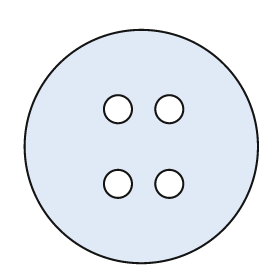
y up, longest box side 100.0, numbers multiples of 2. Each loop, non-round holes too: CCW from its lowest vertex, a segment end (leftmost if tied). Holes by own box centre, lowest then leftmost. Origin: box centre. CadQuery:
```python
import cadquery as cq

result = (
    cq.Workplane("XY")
    .moveTo(0.0, 0.0)
    .circle(50.0)
    .moveTo(-10.0, -16.0)
    .circle(6.0)
    .moveTo(12.0, -16.0)
    .circle(6.0)
    .moveTo(-10.0, 16.0)
    .circle(6.0)
    .moveTo(12.0, 16.0)
    .circle(6.0)
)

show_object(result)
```